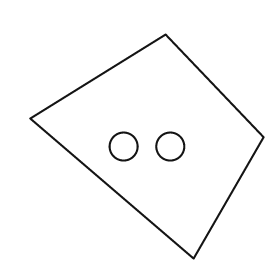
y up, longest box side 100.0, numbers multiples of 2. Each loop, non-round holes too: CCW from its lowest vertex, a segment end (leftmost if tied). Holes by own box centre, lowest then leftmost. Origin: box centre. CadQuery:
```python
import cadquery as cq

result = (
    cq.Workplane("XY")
    .moveTo(20.0, -48.0)
    .lineTo(50.0, 4.0)
    .lineTo(8.0, 48.0)
    .lineTo(-50.0, 12.0)
    .close()
    .moveTo(-10.0, 0.0)
    .circle(6.0)
    .moveTo(10.0, 0.0)
    .circle(6.0)
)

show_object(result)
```